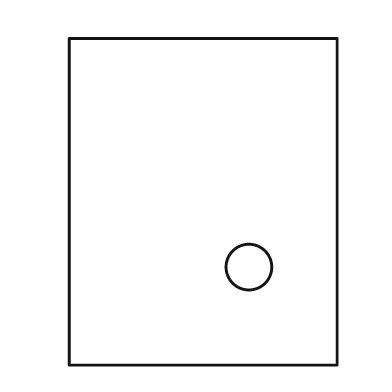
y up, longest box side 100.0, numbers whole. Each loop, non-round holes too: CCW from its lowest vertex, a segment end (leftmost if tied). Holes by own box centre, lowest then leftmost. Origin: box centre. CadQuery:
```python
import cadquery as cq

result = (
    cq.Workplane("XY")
    .moveTo(-41.0, -50.0)
    .lineTo(41.0, -50.0)
    .lineTo(41.0, 50.0)
    .lineTo(-41.0, 50.0)
    .close()
    .moveTo(14.0, -20.0)
    .circle(7.0)
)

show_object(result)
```